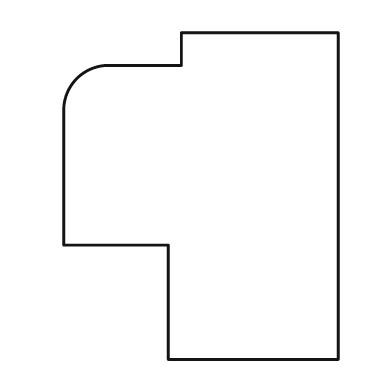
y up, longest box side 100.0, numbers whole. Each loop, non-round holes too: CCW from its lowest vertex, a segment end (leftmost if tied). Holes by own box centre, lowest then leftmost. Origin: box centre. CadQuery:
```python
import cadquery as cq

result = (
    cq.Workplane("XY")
    .moveTo(-10.0, -50.0)
    .lineTo(42.0, -50.0)
    .lineTo(42.0, 50.0)
    .lineTo(-6.0, 50.0)
    .lineTo(-6.0, 40.0)
    .lineTo(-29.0, 40.0)
    .threePointArc((-38.0, 36.0), (-42.0, 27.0))
    .lineTo(-42.0, -15.0)
    .lineTo(-10.0, -15.0)
    .close()
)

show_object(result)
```